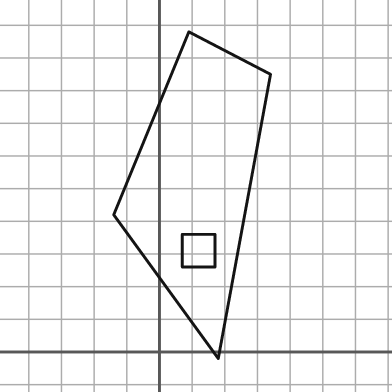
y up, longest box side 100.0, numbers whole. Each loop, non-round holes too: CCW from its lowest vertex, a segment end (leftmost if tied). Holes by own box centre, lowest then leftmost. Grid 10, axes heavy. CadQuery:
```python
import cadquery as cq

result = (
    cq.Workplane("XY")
    .moveTo(18.0, -2.0)
    .lineTo(34.0, 85.0)
    .lineTo(9.0, 98.0)
    .lineTo(-14.0, 42.0)
    .close()
    .moveTo(7.0, 26.0)
    .lineTo(17.0, 26.0)
    .lineTo(17.0, 36.0)
    .lineTo(7.0, 36.0)
    .close()
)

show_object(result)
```